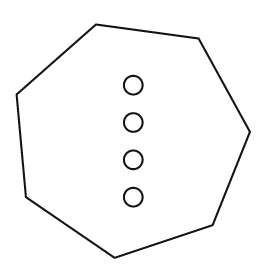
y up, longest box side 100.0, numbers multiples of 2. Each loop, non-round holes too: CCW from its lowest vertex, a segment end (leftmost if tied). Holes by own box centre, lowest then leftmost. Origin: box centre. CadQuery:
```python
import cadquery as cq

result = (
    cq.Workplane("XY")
    .moveTo(-8.0, -50.0)
    .lineTo(34.0, -36.0)
    .lineTo(50.0, 4.0)
    .lineTo(28.0, 44.0)
    .lineTo(-16.0, 50.0)
    .lineTo(-50.0, 20.0)
    .lineTo(-46.0, -24.0)
    .close()
    .moveTo(0.0, -24.0)
    .circle(4.0)
    .moveTo(0.0, -8.0)
    .circle(4.0)
    .moveTo(0.0, 8.0)
    .circle(4.0)
    .moveTo(0.0, 24.0)
    .circle(4.0)
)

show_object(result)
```